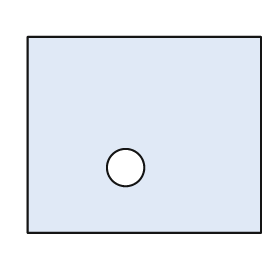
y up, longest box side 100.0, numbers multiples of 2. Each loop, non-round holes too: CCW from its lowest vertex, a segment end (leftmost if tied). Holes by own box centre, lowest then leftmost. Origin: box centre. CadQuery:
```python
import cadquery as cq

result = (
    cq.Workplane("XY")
    .moveTo(-50.0, -42.0)
    .lineTo(50.0, -42.0)
    .lineTo(50.0, 42.0)
    .lineTo(-50.0, 42.0)
    .close()
    .moveTo(-8.0, -14.0)
    .circle(8.0)
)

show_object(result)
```